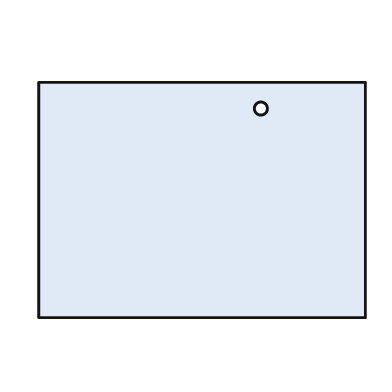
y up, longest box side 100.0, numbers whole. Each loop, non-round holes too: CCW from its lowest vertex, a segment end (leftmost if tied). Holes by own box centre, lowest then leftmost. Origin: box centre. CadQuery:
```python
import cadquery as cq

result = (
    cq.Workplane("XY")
    .moveTo(-50.0, -36.0)
    .lineTo(50.0, -36.0)
    .lineTo(50.0, 36.0)
    .lineTo(-50.0, 36.0)
    .close()
    .moveTo(18.0, 28.0)
    .circle(2.0)
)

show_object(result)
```